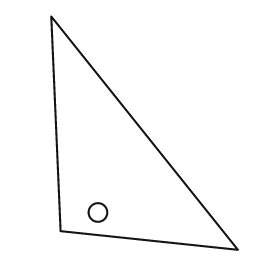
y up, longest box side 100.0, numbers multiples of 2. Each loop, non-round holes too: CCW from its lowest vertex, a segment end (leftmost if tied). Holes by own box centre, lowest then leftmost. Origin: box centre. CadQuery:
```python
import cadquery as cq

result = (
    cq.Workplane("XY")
    .moveTo(40.0, -50.0)
    .lineTo(-40.0, 50.0)
    .lineTo(-36.0, -42.0)
    .close()
    .moveTo(-20.0, -34.0)
    .circle(4.0)
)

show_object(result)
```